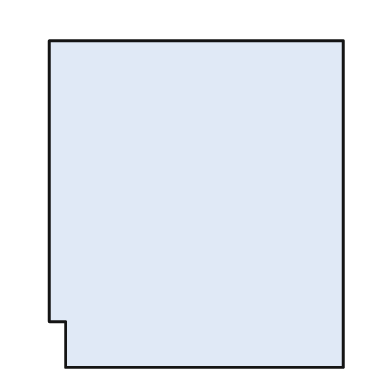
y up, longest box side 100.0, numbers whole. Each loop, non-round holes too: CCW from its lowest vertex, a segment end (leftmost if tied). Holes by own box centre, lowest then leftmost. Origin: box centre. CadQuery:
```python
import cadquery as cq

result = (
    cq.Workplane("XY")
    .moveTo(-40.0, -50.0)
    .lineTo(45.0, -50.0)
    .lineTo(45.0, 50.0)
    .lineTo(-45.0, 50.0)
    .lineTo(-45.0, -36.0)
    .lineTo(-40.0, -36.0)
    .close()
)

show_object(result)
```